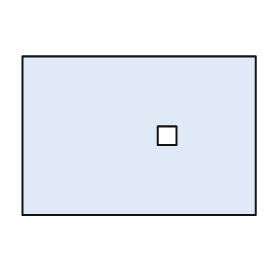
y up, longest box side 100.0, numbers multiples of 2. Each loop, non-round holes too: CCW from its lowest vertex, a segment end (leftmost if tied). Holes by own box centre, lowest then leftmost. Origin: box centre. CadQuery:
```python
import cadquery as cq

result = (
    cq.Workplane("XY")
    .moveTo(-50.0, -34.0)
    .lineTo(50.0, -34.0)
    .lineTo(50.0, 34.0)
    .lineTo(-50.0, 34.0)
    .close()
    .moveTo(8.0, -4.0)
    .lineTo(16.0, -4.0)
    .lineTo(16.0, 4.0)
    .lineTo(8.0, 4.0)
    .close()
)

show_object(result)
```